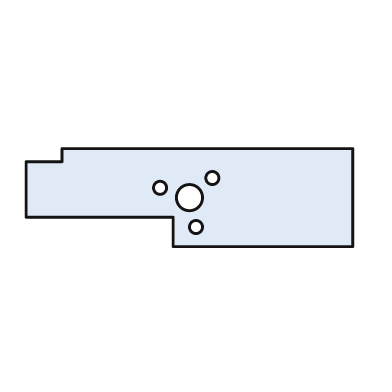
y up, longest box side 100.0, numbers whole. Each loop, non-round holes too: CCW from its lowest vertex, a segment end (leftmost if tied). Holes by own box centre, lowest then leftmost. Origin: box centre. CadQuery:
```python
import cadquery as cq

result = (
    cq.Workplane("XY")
    .moveTo(-5.0, -15.0)
    .lineTo(50.0, -15.0)
    .lineTo(50.0, 15.0)
    .lineTo(-39.0, 15.0)
    .lineTo(-39.0, 11.0)
    .lineTo(-50.0, 11.0)
    .lineTo(-50.0, -6.0)
    .lineTo(-5.0, -6.0)
    .close()
    .moveTo(2.0, -9.0)
    .circle(2.0)
    .moveTo(0.0, 0.0)
    .circle(4.0)
    .moveTo(-9.0, 3.0)
    .circle(2.0)
    .moveTo(7.0, 6.0)
    .circle(2.0)
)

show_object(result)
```